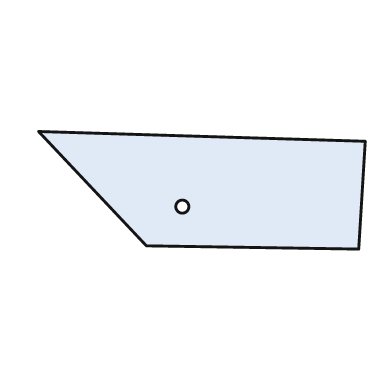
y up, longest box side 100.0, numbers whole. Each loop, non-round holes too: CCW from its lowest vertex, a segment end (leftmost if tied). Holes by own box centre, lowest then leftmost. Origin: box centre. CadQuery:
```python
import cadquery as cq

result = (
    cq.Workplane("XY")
    .moveTo(48.0, -18.0)
    .lineTo(50.0, 15.0)
    .lineTo(-50.0, 18.0)
    .lineTo(-17.0, -17.0)
    .close()
    .moveTo(-6.0, -5.0)
    .circle(2.0)
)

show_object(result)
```